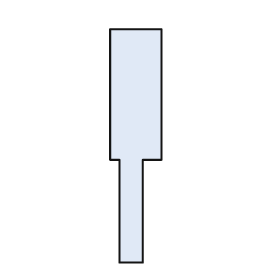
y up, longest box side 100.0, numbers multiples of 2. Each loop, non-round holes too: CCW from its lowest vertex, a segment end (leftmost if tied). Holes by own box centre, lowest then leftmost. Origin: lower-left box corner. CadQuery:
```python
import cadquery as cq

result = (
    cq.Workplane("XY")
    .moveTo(4.0, 0.0)
    .lineTo(14.0, 0.0)
    .lineTo(14.0, 44.0)
    .lineTo(22.0, 44.0)
    .lineTo(22.0, 100.0)
    .lineTo(0.0, 100.0)
    .lineTo(0.0, 44.0)
    .lineTo(4.0, 44.0)
    .close()
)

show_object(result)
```